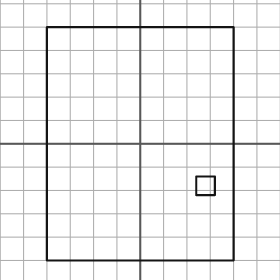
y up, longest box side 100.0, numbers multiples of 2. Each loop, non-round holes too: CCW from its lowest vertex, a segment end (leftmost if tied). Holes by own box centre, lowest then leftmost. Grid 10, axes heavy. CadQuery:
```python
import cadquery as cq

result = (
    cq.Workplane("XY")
    .moveTo(-40.0, -50.0)
    .lineTo(40.0, -50.0)
    .lineTo(40.0, 50.0)
    .lineTo(-40.0, 50.0)
    .close()
    .moveTo(24.0, -22.0)
    .lineTo(32.0, -22.0)
    .lineTo(32.0, -14.0)
    .lineTo(24.0, -14.0)
    .close()
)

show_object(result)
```